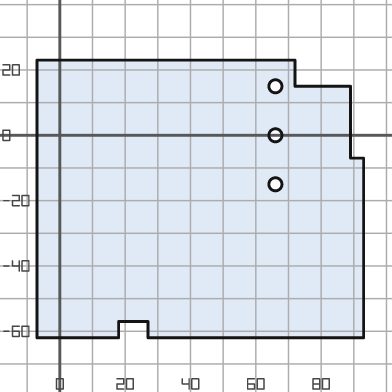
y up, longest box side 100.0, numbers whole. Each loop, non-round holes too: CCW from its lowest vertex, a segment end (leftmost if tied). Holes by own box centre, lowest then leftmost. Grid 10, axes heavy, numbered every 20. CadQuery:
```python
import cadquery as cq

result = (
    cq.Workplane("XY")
    .moveTo(-7.0, -62.0)
    .lineTo(18.0, -62.0)
    .lineTo(18.0, -57.0)
    .lineTo(27.0, -57.0)
    .lineTo(27.0, -62.0)
    .lineTo(93.0, -62.0)
    .lineTo(93.0, -7.0)
    .lineTo(89.0, -7.0)
    .lineTo(89.0, 15.0)
    .lineTo(72.0, 15.0)
    .lineTo(72.0, 23.0)
    .lineTo(-7.0, 23.0)
    .close()
    .moveTo(66.0, -15.0)
    .circle(2.0)
    .moveTo(66.0, 0.0)
    .circle(2.0)
    .moveTo(66.0, 15.0)
    .circle(2.0)
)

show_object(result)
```